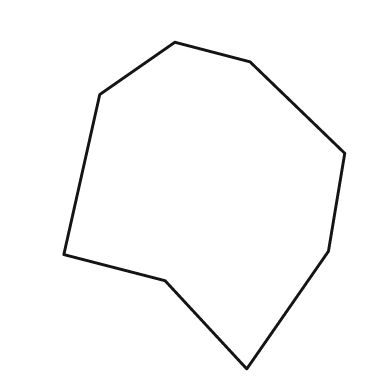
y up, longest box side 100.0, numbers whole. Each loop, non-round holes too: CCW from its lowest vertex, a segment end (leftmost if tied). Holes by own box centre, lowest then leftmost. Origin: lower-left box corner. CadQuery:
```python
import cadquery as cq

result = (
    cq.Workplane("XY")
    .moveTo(56.0, 0.0)
    .lineTo(81.0, 36.0)
    .lineTo(86.0, 66.0)
    .lineTo(57.0, 94.0)
    .lineTo(34.0, 100.0)
    .lineTo(11.0, 84.0)
    .lineTo(0.0, 35.0)
    .lineTo(31.0, 27.0)
    .close()
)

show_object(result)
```